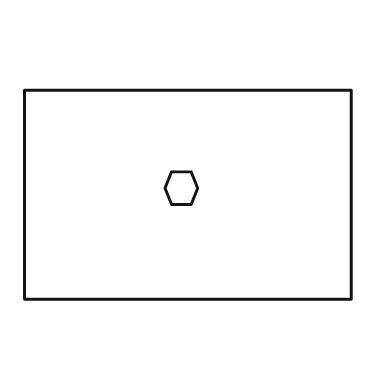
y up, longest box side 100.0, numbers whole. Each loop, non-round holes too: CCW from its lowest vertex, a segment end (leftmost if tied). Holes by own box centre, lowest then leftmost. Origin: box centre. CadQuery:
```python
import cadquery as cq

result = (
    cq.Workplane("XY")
    .moveTo(-50.0, -32.0)
    .lineTo(50.0, -32.0)
    .lineTo(50.0, 32.0)
    .lineTo(-50.0, 32.0)
    .close()
    .moveTo(-5.0, -3.0)
    .lineTo(1.0, -3.0)
    .lineTo(3.0, 2.0)
    .lineTo(1.0, 7.0)
    .lineTo(-5.0, 7.0)
    .lineTo(-7.0, 2.0)
    .close()
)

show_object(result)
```